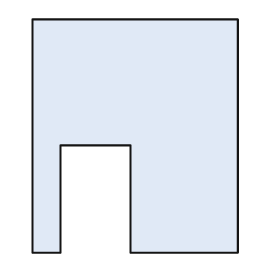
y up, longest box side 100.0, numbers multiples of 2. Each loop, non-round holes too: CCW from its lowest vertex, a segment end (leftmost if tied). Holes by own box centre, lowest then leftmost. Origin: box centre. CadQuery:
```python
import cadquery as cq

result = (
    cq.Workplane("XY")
    .moveTo(-44.0, -50.0)
    .lineTo(-32.0, -50.0)
    .lineTo(-32.0, -4.0)
    .lineTo(-2.0, -4.0)
    .lineTo(-2.0, -50.0)
    .lineTo(44.0, -50.0)
    .lineTo(44.0, 50.0)
    .lineTo(-44.0, 50.0)
    .close()
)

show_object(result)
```